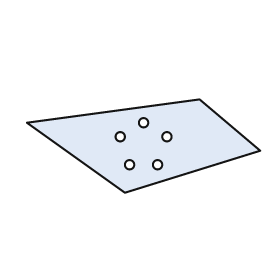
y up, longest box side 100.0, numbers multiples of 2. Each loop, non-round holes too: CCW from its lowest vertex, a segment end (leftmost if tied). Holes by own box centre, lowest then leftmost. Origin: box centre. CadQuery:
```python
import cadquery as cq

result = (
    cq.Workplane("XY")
    .moveTo(-8.0, -20.0)
    .lineTo(50.0, -2.0)
    .lineTo(24.0, 20.0)
    .lineTo(-50.0, 10.0)
    .close()
    .moveTo(-6.0, -8.0)
    .circle(2.0)
    .moveTo(6.0, -8.0)
    .circle(2.0)
    .moveTo(-10.0, 4.0)
    .circle(2.0)
    .moveTo(10.0, 4.0)
    .circle(2.0)
    .moveTo(0.0, 10.0)
    .circle(2.0)
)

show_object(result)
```